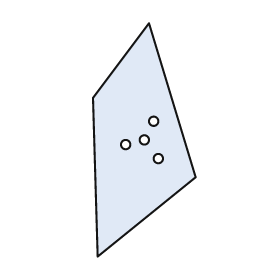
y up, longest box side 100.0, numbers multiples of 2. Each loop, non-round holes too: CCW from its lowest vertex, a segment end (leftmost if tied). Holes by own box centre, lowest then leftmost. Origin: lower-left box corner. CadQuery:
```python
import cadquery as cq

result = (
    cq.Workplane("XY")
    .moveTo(2.0, 0.0)
    .lineTo(44.0, 34.0)
    .lineTo(24.0, 100.0)
    .lineTo(0.0, 68.0)
    .close()
    .moveTo(28.0, 42.0)
    .circle(2.0)
    .moveTo(14.0, 48.0)
    .circle(2.0)
    .moveTo(22.0, 50.0)
    .circle(2.0)
    .moveTo(26.0, 58.0)
    .circle(2.0)
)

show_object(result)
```